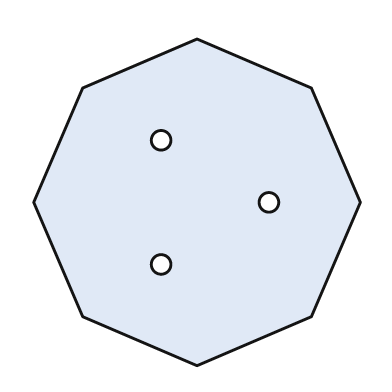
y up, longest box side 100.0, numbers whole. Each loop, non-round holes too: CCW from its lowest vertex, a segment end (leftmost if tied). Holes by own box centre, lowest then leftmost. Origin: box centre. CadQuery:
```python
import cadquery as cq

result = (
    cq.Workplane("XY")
    .moveTo(0.0, -50.0)
    .lineTo(35.0, -35.0)
    .lineTo(50.0, 0.0)
    .lineTo(35.0, 35.0)
    .lineTo(0.0, 50.0)
    .lineTo(-35.0, 35.0)
    .lineTo(-50.0, 0.0)
    .lineTo(-35.0, -35.0)
    .close()
    .moveTo(-11.0, -19.0)
    .circle(3.0)
    .moveTo(22.0, 0.0)
    .circle(3.0)
    .moveTo(-11.0, 19.0)
    .circle(3.0)
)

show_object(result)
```